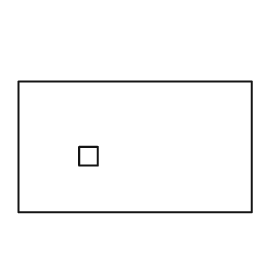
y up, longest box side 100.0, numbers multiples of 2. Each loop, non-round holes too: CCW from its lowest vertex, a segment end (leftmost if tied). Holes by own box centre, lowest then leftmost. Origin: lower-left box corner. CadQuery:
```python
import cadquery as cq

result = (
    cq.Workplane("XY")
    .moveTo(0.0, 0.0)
    .lineTo(100.0, 0.0)
    .lineTo(100.0, 56.0)
    .lineTo(0.0, 56.0)
    .close()
    .moveTo(26.0, 20.0)
    .lineTo(34.0, 20.0)
    .lineTo(34.0, 28.0)
    .lineTo(26.0, 28.0)
    .close()
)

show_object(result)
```